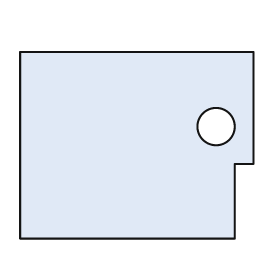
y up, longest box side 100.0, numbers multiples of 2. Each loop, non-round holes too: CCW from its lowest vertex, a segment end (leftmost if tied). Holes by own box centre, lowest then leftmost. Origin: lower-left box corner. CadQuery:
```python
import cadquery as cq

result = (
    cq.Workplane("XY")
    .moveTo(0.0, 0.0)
    .lineTo(92.0, 0.0)
    .lineTo(92.0, 32.0)
    .lineTo(100.0, 32.0)
    .lineTo(100.0, 80.0)
    .lineTo(0.0, 80.0)
    .close()
    .moveTo(84.0, 48.0)
    .circle(8.0)
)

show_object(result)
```